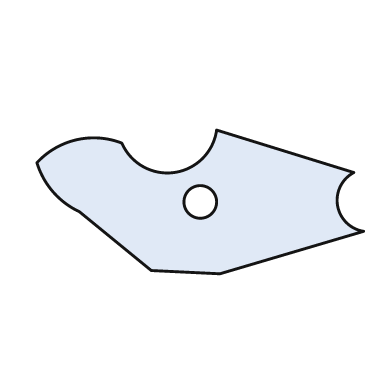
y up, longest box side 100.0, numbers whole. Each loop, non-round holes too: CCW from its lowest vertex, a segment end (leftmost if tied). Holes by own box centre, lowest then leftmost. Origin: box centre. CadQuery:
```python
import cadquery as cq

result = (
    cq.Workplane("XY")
    .moveTo(6.0, -22.0)
    .lineTo(50.0, -9.0)
    .threePointArc((42.0, -1.0), (47.0, 9.0))
    .lineTo(5.0, 22.0)
    .threePointArc((-8.0, 9.0), (-24.0, 18.0))
    .threePointArc((-38.0, 19.0), (-50.0, 12.0))
    .threePointArc((-45.0, 3.0), (-37.0, -3.0))
    .lineTo(-15.0, -21.0)
    .close()
    .moveTo(0.0, 0.0)
    .circle(5.0)
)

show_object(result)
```